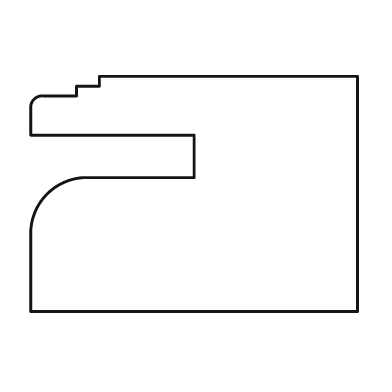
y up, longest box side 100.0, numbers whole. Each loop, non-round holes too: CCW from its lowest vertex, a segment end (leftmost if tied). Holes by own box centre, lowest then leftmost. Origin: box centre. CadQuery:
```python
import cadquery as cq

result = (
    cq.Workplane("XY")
    .moveTo(-50.0, -36.0)
    .lineTo(50.0, -36.0)
    .lineTo(50.0, 36.0)
    .lineTo(-29.0, 36.0)
    .lineTo(-29.0, 33.0)
    .lineTo(-36.0, 33.0)
    .lineTo(-36.0, 30.0)
    .lineTo(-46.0, 30.0)
    .threePointArc((-49.0, 29.0), (-50.0, 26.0))
    .lineTo(-50.0, 18.0)
    .lineTo(0.0, 18.0)
    .lineTo(0.0, 5.0)
    .lineTo(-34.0, 5.0)
    .threePointArc((-45.0, 0.0), (-50.0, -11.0))
    .close()
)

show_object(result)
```